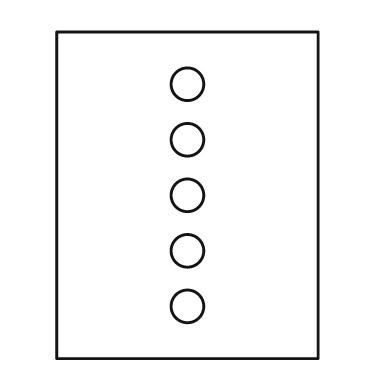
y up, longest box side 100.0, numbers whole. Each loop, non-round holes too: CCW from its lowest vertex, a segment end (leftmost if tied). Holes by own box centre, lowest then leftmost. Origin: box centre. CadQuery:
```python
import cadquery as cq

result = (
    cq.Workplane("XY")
    .moveTo(-40.0, -50.0)
    .lineTo(40.0, -50.0)
    .lineTo(40.0, 50.0)
    .lineTo(-40.0, 50.0)
    .close()
    .moveTo(0.0, -34.0)
    .circle(5.0)
    .moveTo(0.0, -17.0)
    .circle(5.0)
    .moveTo(0.0, 0.0)
    .circle(5.0)
    .moveTo(0.0, 17.0)
    .circle(5.0)
    .moveTo(0.0, 34.0)
    .circle(5.0)
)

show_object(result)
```